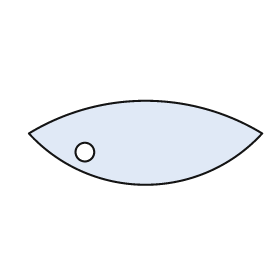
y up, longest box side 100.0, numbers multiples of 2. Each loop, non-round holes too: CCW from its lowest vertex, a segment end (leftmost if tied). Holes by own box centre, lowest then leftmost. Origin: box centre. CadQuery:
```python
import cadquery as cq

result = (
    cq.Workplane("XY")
    .moveTo(-50.0, 4.0)
    .threePointArc((0.0, -18.0), (50.0, 4.0))
    .threePointArc((0.0, 18.0), (-50.0, 4.0))
    .close()
    .moveTo(-26.0, -4.0)
    .circle(4.0)
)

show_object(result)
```